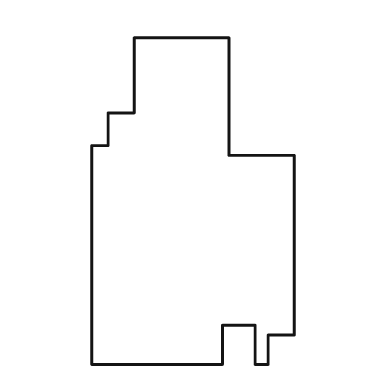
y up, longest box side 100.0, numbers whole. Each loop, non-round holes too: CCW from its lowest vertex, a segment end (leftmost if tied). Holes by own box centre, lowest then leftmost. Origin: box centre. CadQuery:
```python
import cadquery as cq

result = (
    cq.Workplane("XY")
    .moveTo(-31.0, -50.0)
    .lineTo(9.0, -50.0)
    .lineTo(9.0, -38.0)
    .lineTo(19.0, -38.0)
    .lineTo(19.0, -50.0)
    .lineTo(23.0, -50.0)
    .lineTo(23.0, -41.0)
    .lineTo(31.0, -41.0)
    .lineTo(31.0, 14.0)
    .lineTo(11.0, 14.0)
    .lineTo(11.0, 50.0)
    .lineTo(-18.0, 50.0)
    .lineTo(-18.0, 27.0)
    .lineTo(-26.0, 27.0)
    .lineTo(-26.0, 17.0)
    .lineTo(-31.0, 17.0)
    .close()
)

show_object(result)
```